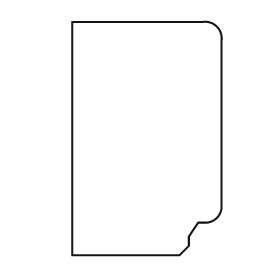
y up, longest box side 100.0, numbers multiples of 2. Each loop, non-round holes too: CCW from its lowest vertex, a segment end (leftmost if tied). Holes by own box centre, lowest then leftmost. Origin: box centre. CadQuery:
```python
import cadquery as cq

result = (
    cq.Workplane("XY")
    .moveTo(-32.0, -50.0)
    .lineTo(14.0, -50.0)
    .lineTo(18.0, -46.0)
    .lineTo(18.0, -42.0)
    .lineTo(22.0, -36.0)
    .lineTo(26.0, -36.0)
    .threePointArc((30.0, -34.0), (32.0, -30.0))
    .lineTo(32.0, 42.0)
    .threePointArc((30.0, 48.0), (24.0, 50.0))
    .lineTo(-32.0, 50.0)
    .close()
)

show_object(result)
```